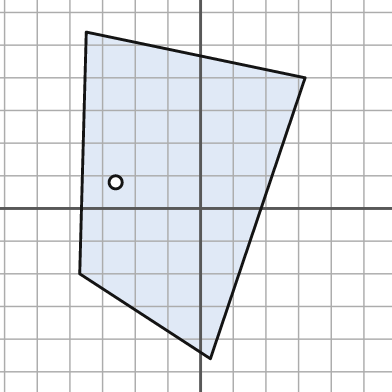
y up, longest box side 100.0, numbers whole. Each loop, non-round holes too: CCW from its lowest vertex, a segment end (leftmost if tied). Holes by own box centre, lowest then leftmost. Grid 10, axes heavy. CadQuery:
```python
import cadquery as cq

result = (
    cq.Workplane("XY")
    .moveTo(3.0, -46.0)
    .lineTo(32.0, 40.0)
    .lineTo(-35.0, 54.0)
    .lineTo(-37.0, -20.0)
    .close()
    .moveTo(-26.0, 8.0)
    .circle(2.0)
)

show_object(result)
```